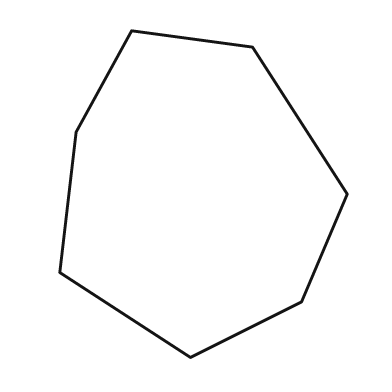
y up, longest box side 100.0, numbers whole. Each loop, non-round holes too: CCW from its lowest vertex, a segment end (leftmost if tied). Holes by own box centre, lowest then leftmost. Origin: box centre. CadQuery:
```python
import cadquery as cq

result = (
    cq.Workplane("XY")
    .moveTo(-4.0, -50.0)
    .lineTo(30.0, -33.0)
    .lineTo(44.0, 0.0)
    .lineTo(15.0, 45.0)
    .lineTo(-22.0, 50.0)
    .lineTo(-39.0, 19.0)
    .lineTo(-44.0, -24.0)
    .close()
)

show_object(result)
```